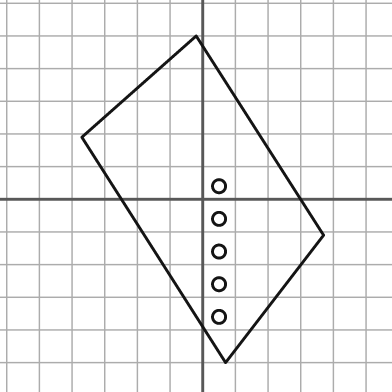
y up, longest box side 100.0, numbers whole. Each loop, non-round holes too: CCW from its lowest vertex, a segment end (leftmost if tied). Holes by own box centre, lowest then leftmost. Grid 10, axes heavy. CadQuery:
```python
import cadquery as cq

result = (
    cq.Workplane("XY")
    .moveTo(7.0, -50.0)
    .lineTo(37.0, -11.0)
    .lineTo(-2.0, 50.0)
    .lineTo(-37.0, 19.0)
    .close()
    .moveTo(5.0, -36.0)
    .circle(2.0)
    .moveTo(5.0, -26.0)
    .circle(2.0)
    .moveTo(5.0, -16.0)
    .circle(2.0)
    .moveTo(5.0, -6.0)
    .circle(2.0)
    .moveTo(5.0, 4.0)
    .circle(2.0)
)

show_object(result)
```